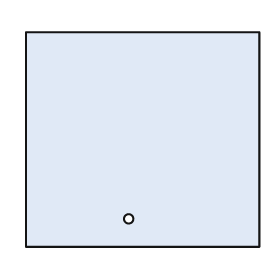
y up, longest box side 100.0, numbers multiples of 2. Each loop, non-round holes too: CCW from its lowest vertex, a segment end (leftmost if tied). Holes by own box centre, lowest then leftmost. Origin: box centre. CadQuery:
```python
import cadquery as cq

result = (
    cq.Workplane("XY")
    .moveTo(-50.0, -46.0)
    .lineTo(50.0, -46.0)
    .lineTo(50.0, 46.0)
    .lineTo(-50.0, 46.0)
    .close()
    .moveTo(-6.0, -34.0)
    .circle(2.0)
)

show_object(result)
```